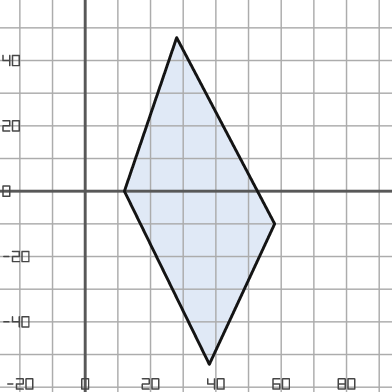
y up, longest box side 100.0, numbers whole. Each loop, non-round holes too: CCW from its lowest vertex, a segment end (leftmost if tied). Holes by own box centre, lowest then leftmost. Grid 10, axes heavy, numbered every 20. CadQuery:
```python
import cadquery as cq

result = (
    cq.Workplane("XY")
    .moveTo(38.0, -53.0)
    .lineTo(58.0, -10.0)
    .lineTo(28.0, 47.0)
    .lineTo(12.0, 0.0)
    .close()
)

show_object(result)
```